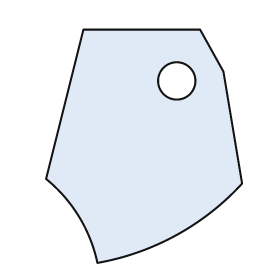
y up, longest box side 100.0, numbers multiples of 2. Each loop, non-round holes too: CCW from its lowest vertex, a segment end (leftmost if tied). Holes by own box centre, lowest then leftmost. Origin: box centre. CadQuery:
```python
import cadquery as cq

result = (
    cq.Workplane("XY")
    .moveTo(-20.0, -50.0)
    .threePointArc((14.0, -38.0), (42.0, -16.0))
    .lineTo(34.0, 32.0)
    .lineTo(24.0, 50.0)
    .lineTo(-26.0, 50.0)
    .lineTo(-42.0, -14.0)
    .threePointArc((-28.0, -30.0), (-20.0, -50.0))
    .close()
    .moveTo(14.0, 28.0)
    .circle(8.0)
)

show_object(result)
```